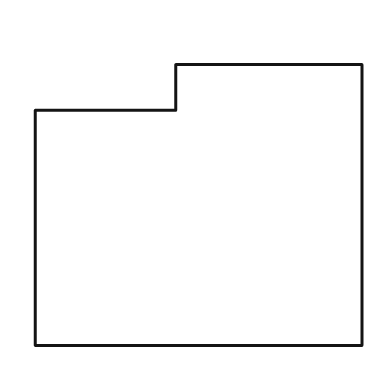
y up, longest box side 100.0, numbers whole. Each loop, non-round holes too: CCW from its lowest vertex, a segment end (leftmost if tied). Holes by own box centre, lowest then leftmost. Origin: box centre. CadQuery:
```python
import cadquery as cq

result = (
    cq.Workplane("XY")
    .moveTo(-50.0, -43.0)
    .lineTo(50.0, -43.0)
    .lineTo(50.0, 43.0)
    .lineTo(-7.0, 43.0)
    .lineTo(-7.0, 29.0)
    .lineTo(-50.0, 29.0)
    .close()
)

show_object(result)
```